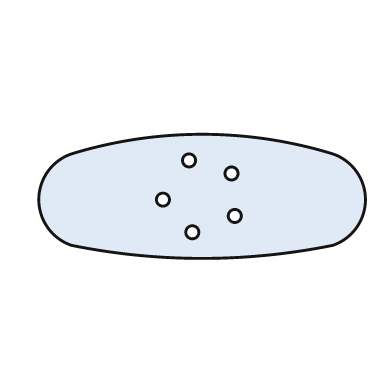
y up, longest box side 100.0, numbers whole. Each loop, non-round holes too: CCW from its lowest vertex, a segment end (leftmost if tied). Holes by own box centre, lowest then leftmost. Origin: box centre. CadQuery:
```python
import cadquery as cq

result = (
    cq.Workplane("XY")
    .moveTo(-40.0, -15.0)
    .threePointArc((0.0, -19.0), (40.0, -15.0))
    .threePointArc((50.0, -1.0), (40.0, 13.0))
    .threePointArc((0.0, 19.0), (-40.0, 13.0))
    .threePointArc((-50.0, -1.0), (-40.0, -15.0))
    .close()
    .moveTo(-3.0, -11.0)
    .circle(2.0)
    .moveTo(10.0, -6.0)
    .circle(2.0)
    .moveTo(-12.0, -1.0)
    .circle(2.0)
    .moveTo(9.0, 7.0)
    .circle(2.0)
    .moveTo(-4.0, 11.0)
    .circle(2.0)
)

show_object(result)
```